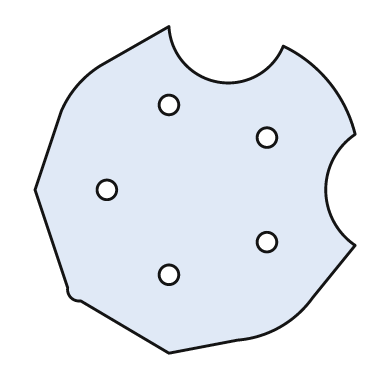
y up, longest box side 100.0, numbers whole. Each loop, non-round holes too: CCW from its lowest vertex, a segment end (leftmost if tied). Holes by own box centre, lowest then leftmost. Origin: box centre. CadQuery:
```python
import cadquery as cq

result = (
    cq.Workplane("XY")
    .moveTo(-8.0, -50.0)
    .lineTo(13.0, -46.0)
    .threePointArc((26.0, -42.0), (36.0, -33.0))
    .lineTo(49.0, -17.0)
    .threePointArc((40.0, 0.0), (49.0, 17.0))
    .threePointArc((41.0, 33.0), (27.0, 44.0))
    .threePointArc((7.0, 33.0), (-8.0, 50.0))
    .lineTo(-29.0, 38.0)
    .threePointArc((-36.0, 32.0), (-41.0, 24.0))
    .lineTo(-49.0, 0.0)
    .lineTo(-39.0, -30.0)
    .threePointArc((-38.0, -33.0), (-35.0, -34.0))
    .close()
    .moveTo(-8.0, -26.0)
    .circle(3.0)
    .moveTo(22.0, -16.0)
    .circle(3.0)
    .moveTo(-27.0, 0.0)
    .circle(3.0)
    .moveTo(22.0, 16.0)
    .circle(3.0)
    .moveTo(-8.0, 26.0)
    .circle(3.0)
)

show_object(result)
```